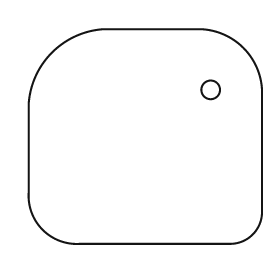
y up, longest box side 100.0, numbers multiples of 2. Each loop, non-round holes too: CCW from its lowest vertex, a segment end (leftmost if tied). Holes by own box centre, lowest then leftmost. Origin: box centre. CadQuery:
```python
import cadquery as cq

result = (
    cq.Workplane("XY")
    .moveTo(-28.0, -46.0)
    .lineTo(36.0, -46.0)
    .threePointArc((46.0, -42.0), (50.0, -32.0))
    .lineTo(50.0, 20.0)
    .threePointArc((42.0, 38.0), (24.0, 46.0))
    .lineTo(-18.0, 46.0)
    .threePointArc((-40.0, 36.0), (-50.0, 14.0))
    .lineTo(-50.0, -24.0)
    .threePointArc((-44.0, -40.0), (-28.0, -46.0))
    .close()
    .moveTo(28.0, 20.0)
    .circle(4.0)
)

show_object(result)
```